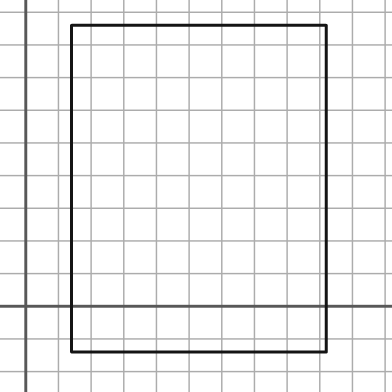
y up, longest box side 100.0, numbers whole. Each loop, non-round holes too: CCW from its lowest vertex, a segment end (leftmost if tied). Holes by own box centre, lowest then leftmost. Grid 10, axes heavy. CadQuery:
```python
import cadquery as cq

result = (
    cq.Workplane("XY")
    .moveTo(14.0, -14.0)
    .lineTo(92.0, -14.0)
    .lineTo(92.0, 86.0)
    .lineTo(14.0, 86.0)
    .close()
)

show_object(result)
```